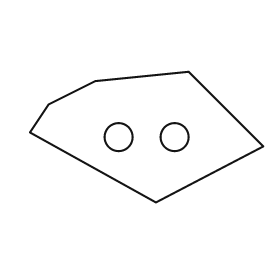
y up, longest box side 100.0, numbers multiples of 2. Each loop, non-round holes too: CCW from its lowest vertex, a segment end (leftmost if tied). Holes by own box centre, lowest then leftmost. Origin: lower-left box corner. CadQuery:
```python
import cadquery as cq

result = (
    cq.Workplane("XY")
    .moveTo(54.0, 0.0)
    .lineTo(100.0, 24.0)
    .lineTo(68.0, 56.0)
    .lineTo(28.0, 52.0)
    .lineTo(8.0, 42.0)
    .lineTo(0.0, 30.0)
    .close()
    .moveTo(38.0, 28.0)
    .circle(6.0)
    .moveTo(62.0, 28.0)
    .circle(6.0)
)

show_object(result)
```